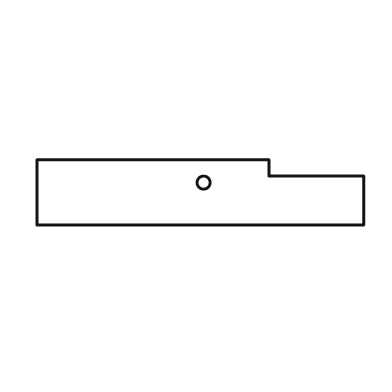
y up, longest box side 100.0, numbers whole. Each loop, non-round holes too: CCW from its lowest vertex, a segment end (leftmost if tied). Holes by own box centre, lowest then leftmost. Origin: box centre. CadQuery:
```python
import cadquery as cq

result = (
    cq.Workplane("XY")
    .moveTo(-50.0, -10.0)
    .lineTo(50.0, -10.0)
    .lineTo(50.0, 5.0)
    .lineTo(21.0, 5.0)
    .lineTo(21.0, 10.0)
    .lineTo(-50.0, 10.0)
    .close()
    .moveTo(1.0, 3.0)
    .circle(2.0)
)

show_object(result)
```